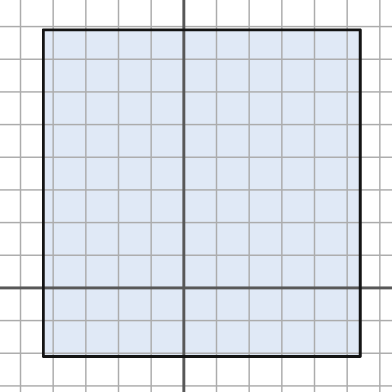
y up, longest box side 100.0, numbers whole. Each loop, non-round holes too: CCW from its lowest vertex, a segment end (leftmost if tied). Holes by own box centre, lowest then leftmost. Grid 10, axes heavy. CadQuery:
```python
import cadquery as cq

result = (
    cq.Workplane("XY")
    .moveTo(-43.0, -21.0)
    .lineTo(54.0, -21.0)
    .lineTo(54.0, 79.0)
    .lineTo(-43.0, 79.0)
    .close()
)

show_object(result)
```